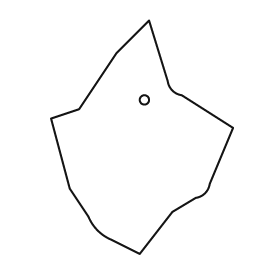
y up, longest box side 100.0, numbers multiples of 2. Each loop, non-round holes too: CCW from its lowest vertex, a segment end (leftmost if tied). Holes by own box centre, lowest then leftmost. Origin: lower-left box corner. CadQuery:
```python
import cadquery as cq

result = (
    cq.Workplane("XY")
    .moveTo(38.0, 0.0)
    .lineTo(52.0, 18.0)
    .lineTo(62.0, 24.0)
    .threePointArc((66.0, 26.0), (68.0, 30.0))
    .lineTo(78.0, 54.0)
    .lineTo(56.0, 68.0)
    .threePointArc((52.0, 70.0), (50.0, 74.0))
    .lineTo(42.0, 100.0)
    .lineTo(28.0, 86.0)
    .lineTo(12.0, 62.0)
    .lineTo(0.0, 58.0)
    .lineTo(8.0, 28.0)
    .lineTo(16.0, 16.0)
    .threePointArc((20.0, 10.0), (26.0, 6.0))
    .close()
    .moveTo(40.0, 66.0)
    .circle(2.0)
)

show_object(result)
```